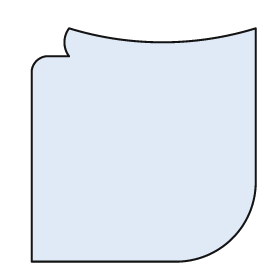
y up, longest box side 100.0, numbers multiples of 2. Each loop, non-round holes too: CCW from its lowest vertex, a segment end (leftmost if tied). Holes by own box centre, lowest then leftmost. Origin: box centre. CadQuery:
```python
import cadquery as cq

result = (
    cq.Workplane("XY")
    .moveTo(-48.0, -50.0)
    .lineTo(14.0, -50.0)
    .threePointArc((38.0, -40.0), (48.0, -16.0))
    .lineTo(48.0, 50.0)
    .threePointArc((8.0, 44.0), (-32.0, 50.0))
    .threePointArc((-34.0, 44.0), (-32.0, 38.0))
    .lineTo(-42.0, 38.0)
    .threePointArc((-46.0, 36.0), (-48.0, 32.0))
    .close()
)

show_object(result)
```